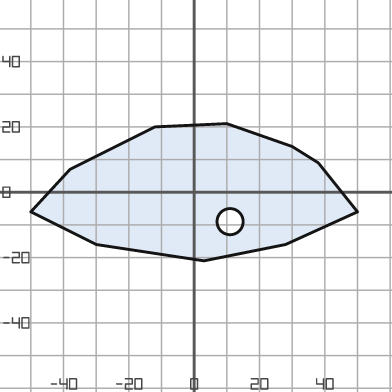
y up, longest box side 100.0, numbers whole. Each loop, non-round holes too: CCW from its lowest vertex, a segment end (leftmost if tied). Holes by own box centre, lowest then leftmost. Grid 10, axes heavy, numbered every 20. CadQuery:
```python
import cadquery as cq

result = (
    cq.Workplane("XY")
    .moveTo(3.0, -21.0)
    .lineTo(28.0, -16.0)
    .lineTo(50.0, -6.0)
    .lineTo(38.0, 9.0)
    .lineTo(30.0, 14.0)
    .lineTo(10.0, 21.0)
    .lineTo(-12.0, 20.0)
    .lineTo(-38.0, 7.0)
    .lineTo(-50.0, -6.0)
    .lineTo(-30.0, -16.0)
    .close()
    .moveTo(11.0, -9.0)
    .circle(4.0)
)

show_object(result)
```